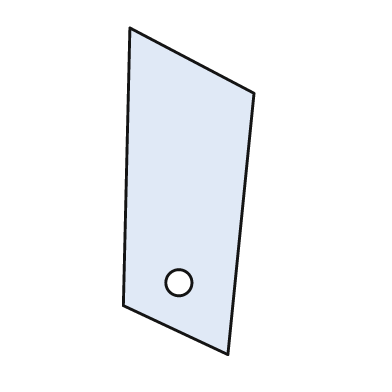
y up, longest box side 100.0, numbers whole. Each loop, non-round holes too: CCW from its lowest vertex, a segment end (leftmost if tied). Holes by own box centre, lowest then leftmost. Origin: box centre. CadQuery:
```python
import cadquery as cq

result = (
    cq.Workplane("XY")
    .moveTo(12.0, -50.0)
    .lineTo(20.0, 30.0)
    .lineTo(-18.0, 50.0)
    .lineTo(-20.0, -35.0)
    .close()
    .moveTo(-3.0, -28.0)
    .circle(4.0)
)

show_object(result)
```